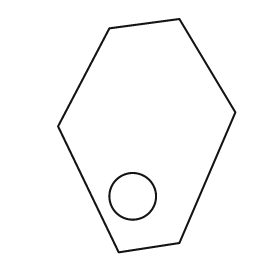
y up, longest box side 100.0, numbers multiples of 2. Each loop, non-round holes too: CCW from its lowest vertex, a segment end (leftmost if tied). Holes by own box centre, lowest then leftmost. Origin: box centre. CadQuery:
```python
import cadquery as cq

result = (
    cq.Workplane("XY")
    .moveTo(-12.0, -50.0)
    .lineTo(14.0, -46.0)
    .lineTo(38.0, 10.0)
    .lineTo(14.0, 50.0)
    .lineTo(-16.0, 46.0)
    .lineTo(-38.0, 4.0)
    .close()
    .moveTo(-6.0, -26.0)
    .circle(10.0)
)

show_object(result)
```